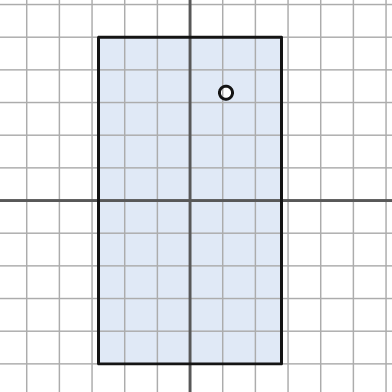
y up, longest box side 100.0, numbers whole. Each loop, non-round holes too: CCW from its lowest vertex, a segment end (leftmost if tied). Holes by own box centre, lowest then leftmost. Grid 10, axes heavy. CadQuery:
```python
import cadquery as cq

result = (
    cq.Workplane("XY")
    .moveTo(-28.0, -50.0)
    .lineTo(28.0, -50.0)
    .lineTo(28.0, 50.0)
    .lineTo(-28.0, 50.0)
    .close()
    .moveTo(11.0, 33.0)
    .circle(2.0)
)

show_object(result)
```